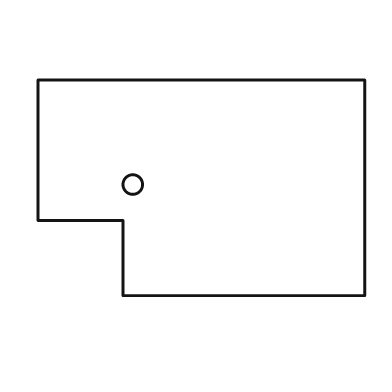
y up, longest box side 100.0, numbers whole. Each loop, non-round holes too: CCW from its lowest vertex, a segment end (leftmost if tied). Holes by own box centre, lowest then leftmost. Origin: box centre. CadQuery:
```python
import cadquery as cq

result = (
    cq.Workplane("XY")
    .moveTo(-24.0, -33.0)
    .lineTo(50.0, -33.0)
    .lineTo(50.0, 33.0)
    .lineTo(-50.0, 33.0)
    .lineTo(-50.0, -10.0)
    .lineTo(-24.0, -10.0)
    .close()
    .moveTo(-21.0, 1.0)
    .circle(3.0)
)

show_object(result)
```